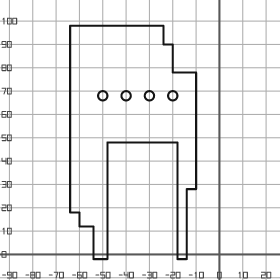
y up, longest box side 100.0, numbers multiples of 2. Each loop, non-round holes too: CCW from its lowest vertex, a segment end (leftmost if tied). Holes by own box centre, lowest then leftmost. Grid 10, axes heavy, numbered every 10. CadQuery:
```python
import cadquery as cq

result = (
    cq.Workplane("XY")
    .moveTo(-54.0, -2.0)
    .lineTo(-48.0, -2.0)
    .lineTo(-48.0, 48.0)
    .lineTo(-18.0, 48.0)
    .lineTo(-18.0, -2.0)
    .lineTo(-14.0, -2.0)
    .lineTo(-14.0, 28.0)
    .lineTo(-10.0, 28.0)
    .lineTo(-10.0, 78.0)
    .lineTo(-20.0, 78.0)
    .lineTo(-20.0, 90.0)
    .lineTo(-24.0, 90.0)
    .lineTo(-24.0, 98.0)
    .lineTo(-64.0, 98.0)
    .lineTo(-64.0, 18.0)
    .lineTo(-60.0, 18.0)
    .lineTo(-60.0, 12.0)
    .lineTo(-54.0, 12.0)
    .close()
    .moveTo(-50.0, 68.0)
    .circle(2.0)
    .moveTo(-40.0, 68.0)
    .circle(2.0)
    .moveTo(-30.0, 68.0)
    .circle(2.0)
    .moveTo(-20.0, 68.0)
    .circle(2.0)
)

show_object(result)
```